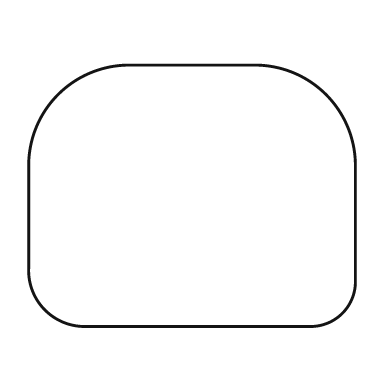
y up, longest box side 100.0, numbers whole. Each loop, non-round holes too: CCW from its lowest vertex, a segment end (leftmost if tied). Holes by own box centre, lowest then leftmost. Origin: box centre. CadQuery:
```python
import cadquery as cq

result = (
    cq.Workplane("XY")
    .moveTo(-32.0, -40.0)
    .lineTo(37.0, -40.0)
    .threePointArc((46.0, -36.0), (50.0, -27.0))
    .lineTo(50.0, 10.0)
    .threePointArc((41.0, 31.0), (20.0, 40.0))
    .lineTo(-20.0, 40.0)
    .threePointArc((-41.0, 31.0), (-50.0, 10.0))
    .lineTo(-50.0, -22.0)
    .threePointArc((-45.0, -35.0), (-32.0, -40.0))
    .close()
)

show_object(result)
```